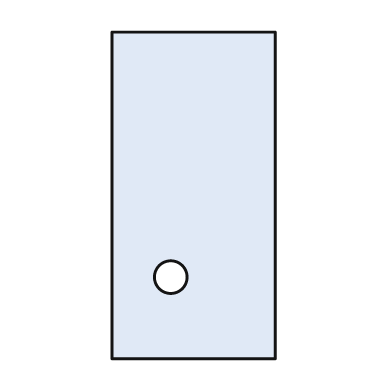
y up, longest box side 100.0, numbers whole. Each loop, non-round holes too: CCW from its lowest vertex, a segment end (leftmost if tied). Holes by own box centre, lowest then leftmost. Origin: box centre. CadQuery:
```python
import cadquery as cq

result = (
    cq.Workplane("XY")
    .moveTo(-25.0, -50.0)
    .lineTo(25.0, -50.0)
    .lineTo(25.0, 50.0)
    .lineTo(-25.0, 50.0)
    .close()
    .moveTo(-7.0, -25.0)
    .circle(5.0)
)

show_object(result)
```